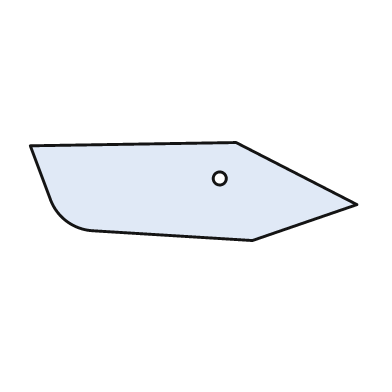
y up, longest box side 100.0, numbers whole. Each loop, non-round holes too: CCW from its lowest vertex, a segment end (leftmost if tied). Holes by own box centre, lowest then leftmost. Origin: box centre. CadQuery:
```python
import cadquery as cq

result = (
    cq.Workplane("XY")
    .moveTo(18.0, -15.0)
    .lineTo(50.0, -4.0)
    .lineTo(13.0, 15.0)
    .lineTo(-50.0, 14.0)
    .lineTo(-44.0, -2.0)
    .threePointArc((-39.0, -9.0), (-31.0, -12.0))
    .close()
    .moveTo(8.0, 4.0)
    .circle(2.0)
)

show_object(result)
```